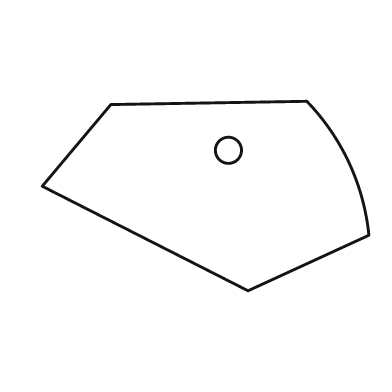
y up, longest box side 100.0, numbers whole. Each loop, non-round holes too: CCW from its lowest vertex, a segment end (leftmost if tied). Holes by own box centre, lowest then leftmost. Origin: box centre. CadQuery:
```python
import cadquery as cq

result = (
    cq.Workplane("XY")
    .moveTo(13.0, -29.0)
    .lineTo(50.0, -12.0)
    .threePointArc((44.0, 10.0), (31.0, 29.0))
    .lineTo(-29.0, 28.0)
    .lineTo(-50.0, 3.0)
    .close()
    .moveTo(7.0, 14.0)
    .circle(4.0)
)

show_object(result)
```